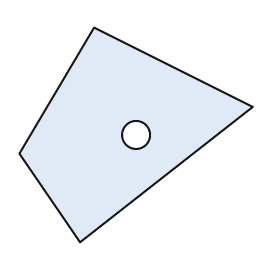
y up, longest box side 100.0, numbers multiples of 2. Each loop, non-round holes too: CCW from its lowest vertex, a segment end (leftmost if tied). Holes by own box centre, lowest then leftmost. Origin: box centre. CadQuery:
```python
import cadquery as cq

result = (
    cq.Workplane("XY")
    .moveTo(-24.0, -46.0)
    .lineTo(50.0, 12.0)
    .lineTo(-18.0, 46.0)
    .lineTo(-50.0, -8.0)
    .close()
    .moveTo(0.0, 0.0)
    .circle(6.0)
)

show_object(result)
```